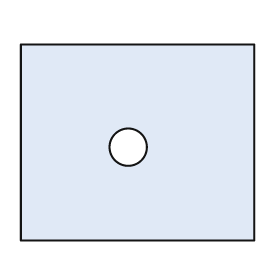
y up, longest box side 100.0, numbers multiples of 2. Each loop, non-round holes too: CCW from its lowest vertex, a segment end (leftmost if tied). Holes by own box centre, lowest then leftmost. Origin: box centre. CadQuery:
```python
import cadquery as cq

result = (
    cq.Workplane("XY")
    .moveTo(-50.0, -42.0)
    .lineTo(50.0, -42.0)
    .lineTo(50.0, 42.0)
    .lineTo(-50.0, 42.0)
    .close()
    .moveTo(-4.0, -2.0)
    .circle(8.0)
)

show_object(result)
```